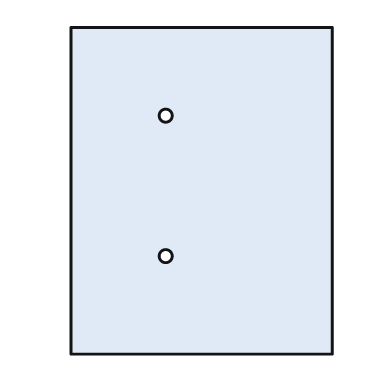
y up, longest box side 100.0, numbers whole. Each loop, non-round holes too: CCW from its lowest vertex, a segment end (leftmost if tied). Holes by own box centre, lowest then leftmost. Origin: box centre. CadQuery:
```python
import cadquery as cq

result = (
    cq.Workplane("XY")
    .moveTo(-40.0, -50.0)
    .lineTo(40.0, -50.0)
    .lineTo(40.0, 50.0)
    .lineTo(-40.0, 50.0)
    .close()
    .moveTo(-11.0, -20.0)
    .circle(2.0)
    .moveTo(-11.0, 23.0)
    .circle(2.0)
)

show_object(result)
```